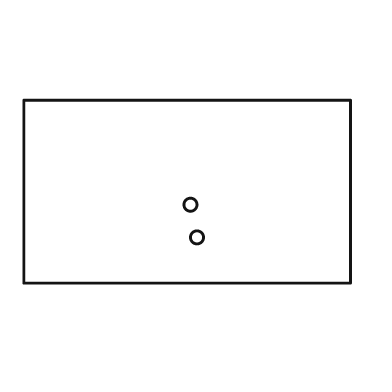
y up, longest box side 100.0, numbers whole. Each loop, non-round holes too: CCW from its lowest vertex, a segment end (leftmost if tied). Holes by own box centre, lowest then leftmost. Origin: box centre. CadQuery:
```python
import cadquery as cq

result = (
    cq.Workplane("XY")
    .moveTo(-50.0, -28.0)
    .lineTo(50.0, -28.0)
    .lineTo(50.0, 28.0)
    .lineTo(-50.0, 28.0)
    .close()
    .moveTo(3.0, -14.0)
    .circle(2.0)
    .moveTo(1.0, -4.0)
    .circle(2.0)
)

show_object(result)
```